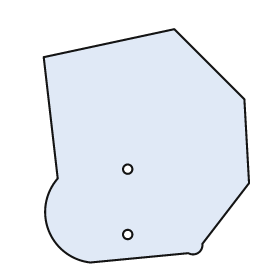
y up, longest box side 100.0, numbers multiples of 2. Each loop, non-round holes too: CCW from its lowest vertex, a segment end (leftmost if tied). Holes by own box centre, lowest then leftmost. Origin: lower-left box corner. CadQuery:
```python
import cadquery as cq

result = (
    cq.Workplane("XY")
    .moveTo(20.0, 0.0)
    .lineTo(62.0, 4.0)
    .threePointArc((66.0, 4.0), (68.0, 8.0))
    .lineTo(88.0, 34.0)
    .lineTo(86.0, 70.0)
    .lineTo(56.0, 100.0)
    .lineTo(0.0, 88.0)
    .lineTo(6.0, 36.0)
    .threePointArc((2.0, 14.0), (20.0, 0.0))
    .close()
    .moveTo(36.0, 12.0)
    .circle(2.0)
    .moveTo(36.0, 40.0)
    .circle(2.0)
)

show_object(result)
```